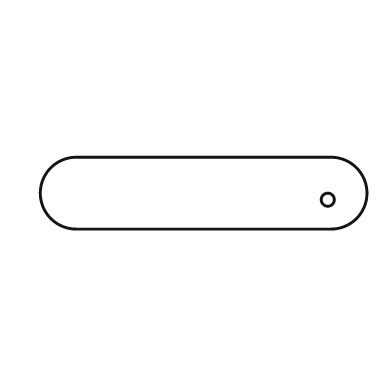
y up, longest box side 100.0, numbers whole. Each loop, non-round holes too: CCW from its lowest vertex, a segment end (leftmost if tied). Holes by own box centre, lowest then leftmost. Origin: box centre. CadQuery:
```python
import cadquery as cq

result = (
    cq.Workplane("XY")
    .moveTo(-39.0, -11.0)
    .lineTo(39.0, -11.0)
    .threePointArc((50.0, 0.0), (39.0, 11.0))
    .lineTo(-39.0, 11.0)
    .threePointArc((-50.0, 0.0), (-39.0, -11.0))
    .close()
    .moveTo(38.0, -2.0)
    .circle(2.0)
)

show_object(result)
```